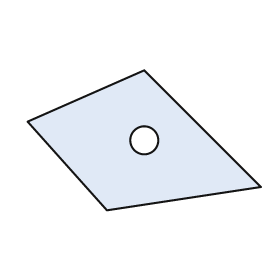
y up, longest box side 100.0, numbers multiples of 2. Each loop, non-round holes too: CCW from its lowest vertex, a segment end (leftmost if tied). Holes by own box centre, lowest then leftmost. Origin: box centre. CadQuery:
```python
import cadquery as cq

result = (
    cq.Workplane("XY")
    .moveTo(-16.0, -30.0)
    .lineTo(50.0, -20.0)
    .lineTo(0.0, 30.0)
    .lineTo(-50.0, 8.0)
    .close()
    .moveTo(0.0, 0.0)
    .circle(6.0)
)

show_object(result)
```